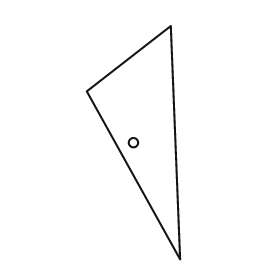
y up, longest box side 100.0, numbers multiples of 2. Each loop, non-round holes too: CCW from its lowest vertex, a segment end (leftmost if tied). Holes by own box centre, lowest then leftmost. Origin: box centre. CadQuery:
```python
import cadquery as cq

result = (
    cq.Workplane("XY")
    .moveTo(20.0, -50.0)
    .lineTo(16.0, 50.0)
    .lineTo(-20.0, 22.0)
    .close()
    .moveTo(0.0, 0.0)
    .circle(2.0)
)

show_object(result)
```